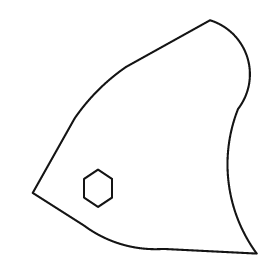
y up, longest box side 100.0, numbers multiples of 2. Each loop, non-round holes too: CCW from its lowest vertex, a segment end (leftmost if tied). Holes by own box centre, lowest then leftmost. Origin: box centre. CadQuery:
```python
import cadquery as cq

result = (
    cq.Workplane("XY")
    .moveTo(48.0, -50.0)
    .threePointArc((36.0, -20.0), (40.0, 12.0))
    .threePointArc((44.0, 34.0), (28.0, 50.0))
    .lineTo(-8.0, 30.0)
    .threePointArc((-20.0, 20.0), (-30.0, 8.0))
    .lineTo(-48.0, -24.0)
    .lineTo(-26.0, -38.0)
    .threePointArc((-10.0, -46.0), (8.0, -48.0))
    .close()
    .moveTo(-20.0, -30.0)
    .lineTo(-14.0, -26.0)
    .lineTo(-14.0, -18.0)
    .lineTo(-20.0, -14.0)
    .lineTo(-26.0, -18.0)
    .lineTo(-26.0, -26.0)
    .close()
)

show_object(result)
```